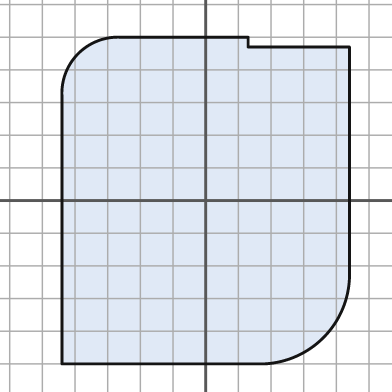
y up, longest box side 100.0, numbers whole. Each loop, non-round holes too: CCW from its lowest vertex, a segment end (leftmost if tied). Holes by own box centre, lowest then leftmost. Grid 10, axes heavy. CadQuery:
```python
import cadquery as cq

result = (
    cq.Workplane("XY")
    .moveTo(-44.0, -50.0)
    .lineTo(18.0, -50.0)
    .threePointArc((36.0, -42.0), (44.0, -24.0))
    .lineTo(44.0, 47.0)
    .lineTo(13.0, 47.0)
    .lineTo(13.0, 50.0)
    .lineTo(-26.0, 50.0)
    .threePointArc((-39.0, 45.0), (-44.0, 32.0))
    .close()
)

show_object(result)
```